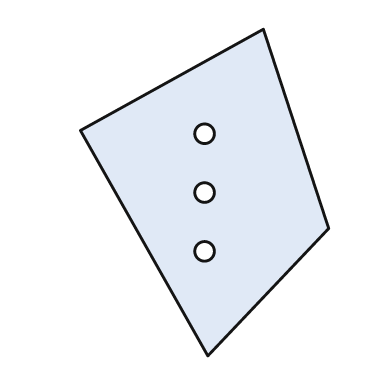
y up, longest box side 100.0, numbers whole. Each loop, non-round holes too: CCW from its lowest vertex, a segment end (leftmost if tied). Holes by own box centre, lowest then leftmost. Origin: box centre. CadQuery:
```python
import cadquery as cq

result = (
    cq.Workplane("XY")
    .moveTo(1.0, -50.0)
    .lineTo(38.0, -11.0)
    .lineTo(18.0, 50.0)
    .lineTo(-38.0, 19.0)
    .close()
    .moveTo(0.0, -18.0)
    .circle(3.0)
    .moveTo(0.0, 0.0)
    .circle(3.0)
    .moveTo(0.0, 18.0)
    .circle(3.0)
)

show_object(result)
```